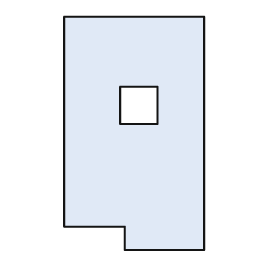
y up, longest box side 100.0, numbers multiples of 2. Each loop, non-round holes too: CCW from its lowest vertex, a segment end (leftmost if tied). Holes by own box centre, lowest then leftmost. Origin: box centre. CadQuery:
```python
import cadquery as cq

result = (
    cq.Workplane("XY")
    .moveTo(-4.0, -50.0)
    .lineTo(30.0, -50.0)
    .lineTo(30.0, 50.0)
    .lineTo(-30.0, 50.0)
    .lineTo(-30.0, -40.0)
    .lineTo(-4.0, -40.0)
    .close()
    .moveTo(-6.0, 4.0)
    .lineTo(10.0, 4.0)
    .lineTo(10.0, 20.0)
    .lineTo(-6.0, 20.0)
    .close()
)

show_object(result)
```